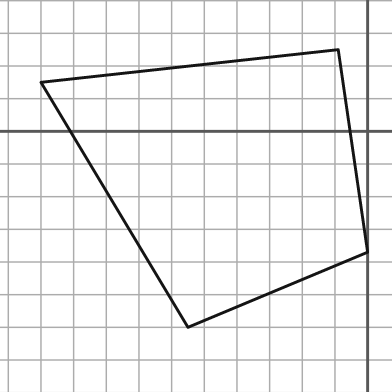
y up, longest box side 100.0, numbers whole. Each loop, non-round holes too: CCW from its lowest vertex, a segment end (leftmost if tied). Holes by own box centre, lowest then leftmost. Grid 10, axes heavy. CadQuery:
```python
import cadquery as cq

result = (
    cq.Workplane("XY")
    .moveTo(-55.0, -60.0)
    .lineTo(0.0, -37.0)
    .lineTo(-9.0, 25.0)
    .lineTo(-100.0, 15.0)
    .close()
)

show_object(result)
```